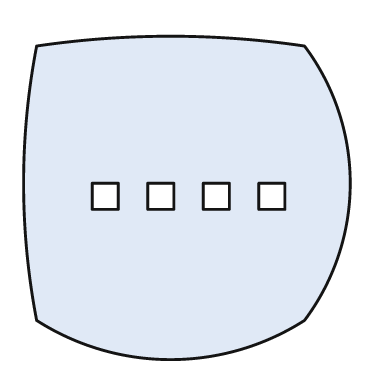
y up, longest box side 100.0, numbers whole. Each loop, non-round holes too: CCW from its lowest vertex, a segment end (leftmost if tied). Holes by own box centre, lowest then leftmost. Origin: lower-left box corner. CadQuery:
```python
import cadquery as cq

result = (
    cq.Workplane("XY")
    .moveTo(4.0, 12.0)
    .threePointArc((45.0, 0.0), (86.0, 12.0))
    .threePointArc((100.0, 54.0), (86.0, 96.0))
    .threePointArc((45.0, 99.0), (4.0, 96.0))
    .threePointArc((0.0, 54.0), (4.0, 12.0))
    .close()
    .moveTo(21.0, 46.0)
    .lineTo(29.0, 46.0)
    .lineTo(29.0, 54.0)
    .lineTo(21.0, 54.0)
    .close()
    .moveTo(38.0, 46.0)
    .lineTo(46.0, 46.0)
    .lineTo(46.0, 54.0)
    .lineTo(38.0, 54.0)
    .close()
    .moveTo(55.0, 46.0)
    .lineTo(63.0, 46.0)
    .lineTo(63.0, 54.0)
    .lineTo(55.0, 54.0)
    .close()
    .moveTo(72.0, 46.0)
    .lineTo(80.0, 46.0)
    .lineTo(80.0, 54.0)
    .lineTo(72.0, 54.0)
    .close()
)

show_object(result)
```